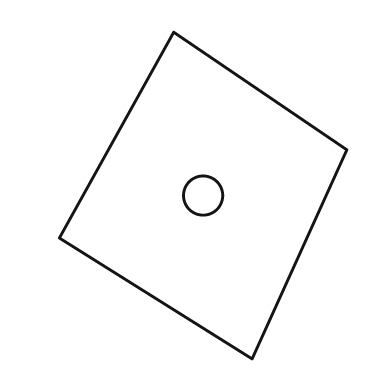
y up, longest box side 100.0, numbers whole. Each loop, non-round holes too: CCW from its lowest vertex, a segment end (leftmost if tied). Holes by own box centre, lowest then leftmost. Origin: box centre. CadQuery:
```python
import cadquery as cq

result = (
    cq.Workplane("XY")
    .moveTo(15.0, -50.0)
    .lineTo(44.0, 14.0)
    .lineTo(-9.0, 50.0)
    .lineTo(-44.0, -13.0)
    .close()
    .moveTo(0.0, 0.0)
    .circle(6.0)
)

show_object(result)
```